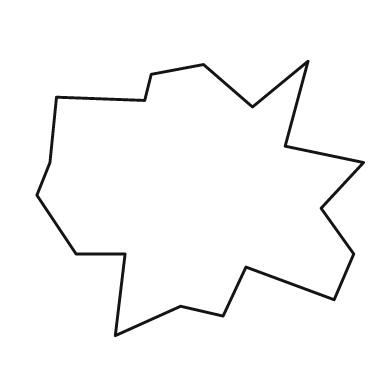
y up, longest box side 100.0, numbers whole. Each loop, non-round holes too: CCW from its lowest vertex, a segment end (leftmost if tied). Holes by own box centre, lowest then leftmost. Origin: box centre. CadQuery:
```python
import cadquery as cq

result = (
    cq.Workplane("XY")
    .moveTo(-26.0, -42.0)
    .lineTo(-6.0, -33.0)
    .lineTo(7.0, -36.0)
    .lineTo(14.0, -21.0)
    .lineTo(41.0, -31.0)
    .lineTo(47.0, -17.0)
    .lineTo(37.0, -3.0)
    .lineTo(50.0, 11.0)
    .lineTo(26.0, 16.0)
    .lineTo(33.0, 42.0)
    .lineTo(16.0, 28.0)
    .lineTo(1.0, 41.0)
    .lineTo(-15.0, 38.0)
    .lineTo(-17.0, 30.0)
    .lineTo(-44.0, 31.0)
    .lineTo(-46.0, 11.0)
    .lineTo(-50.0, 1.0)
    .lineTo(-38.0, -17.0)
    .lineTo(-23.0, -17.0)
    .close()
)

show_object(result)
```